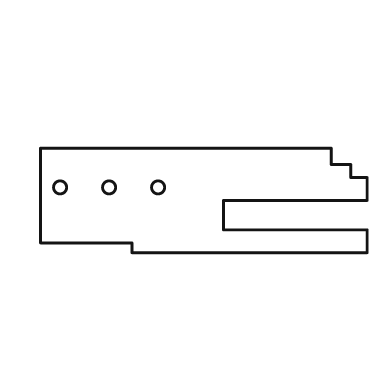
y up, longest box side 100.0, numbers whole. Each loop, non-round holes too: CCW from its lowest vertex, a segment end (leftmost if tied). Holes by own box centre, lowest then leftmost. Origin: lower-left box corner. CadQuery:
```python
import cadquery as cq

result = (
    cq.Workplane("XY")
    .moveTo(28.0, 0.0)
    .lineTo(100.0, 0.0)
    .lineTo(100.0, 7.0)
    .lineTo(56.0, 7.0)
    .lineTo(56.0, 16.0)
    .lineTo(100.0, 16.0)
    .lineTo(100.0, 23.0)
    .lineTo(95.0, 23.0)
    .lineTo(95.0, 27.0)
    .lineTo(89.0, 27.0)
    .lineTo(89.0, 32.0)
    .lineTo(0.0, 32.0)
    .lineTo(0.0, 3.0)
    .lineTo(28.0, 3.0)
    .close()
    .moveTo(6.0, 20.0)
    .circle(2.0)
    .moveTo(21.0, 20.0)
    .circle(2.0)
    .moveTo(36.0, 20.0)
    .circle(2.0)
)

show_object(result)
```